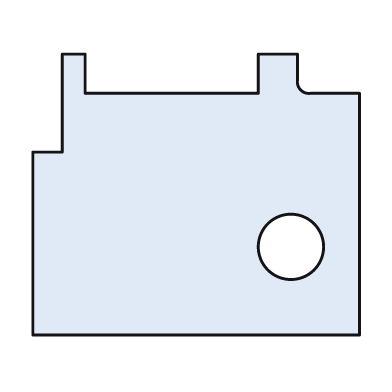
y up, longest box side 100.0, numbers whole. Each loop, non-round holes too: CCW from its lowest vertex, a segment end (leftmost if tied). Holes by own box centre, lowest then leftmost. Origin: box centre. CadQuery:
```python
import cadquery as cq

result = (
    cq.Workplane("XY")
    .moveTo(-50.0, -43.0)
    .lineTo(50.0, -43.0)
    .lineTo(50.0, 31.0)
    .lineTo(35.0, 31.0)
    .threePointArc((32.0, 32.0), (31.0, 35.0))
    .lineTo(31.0, 43.0)
    .lineTo(19.0, 43.0)
    .lineTo(19.0, 31.0)
    .lineTo(-34.0, 31.0)
    .lineTo(-34.0, 43.0)
    .lineTo(-41.0, 43.0)
    .lineTo(-41.0, 13.0)
    .lineTo(-50.0, 13.0)
    .close()
    .moveTo(29.0, -16.0)
    .circle(10.0)
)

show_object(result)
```